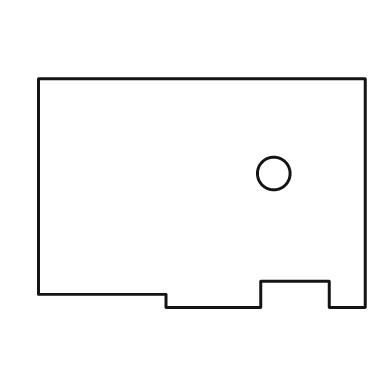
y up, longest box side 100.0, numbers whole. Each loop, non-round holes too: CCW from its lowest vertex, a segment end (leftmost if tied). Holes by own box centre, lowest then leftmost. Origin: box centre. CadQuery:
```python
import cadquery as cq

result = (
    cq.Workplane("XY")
    .moveTo(-11.0, -35.0)
    .lineTo(18.0, -35.0)
    .lineTo(18.0, -27.0)
    .lineTo(39.0, -27.0)
    .lineTo(39.0, -35.0)
    .lineTo(50.0, -35.0)
    .lineTo(50.0, 35.0)
    .lineTo(-50.0, 35.0)
    .lineTo(-50.0, -31.0)
    .lineTo(-11.0, -31.0)
    .close()
    .moveTo(22.0, 6.0)
    .circle(5.0)
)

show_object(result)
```